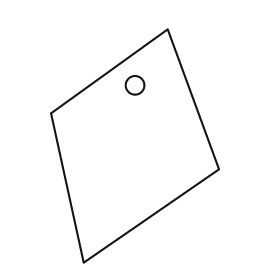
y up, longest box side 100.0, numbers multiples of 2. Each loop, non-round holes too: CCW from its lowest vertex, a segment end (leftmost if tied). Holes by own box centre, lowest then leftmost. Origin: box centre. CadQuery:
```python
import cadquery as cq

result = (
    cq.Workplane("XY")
    .moveTo(-22.0, -50.0)
    .lineTo(36.0, -10.0)
    .lineTo(14.0, 50.0)
    .lineTo(-36.0, 14.0)
    .close()
    .moveTo(0.0, 26.0)
    .circle(4.0)
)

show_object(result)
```